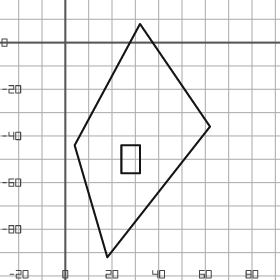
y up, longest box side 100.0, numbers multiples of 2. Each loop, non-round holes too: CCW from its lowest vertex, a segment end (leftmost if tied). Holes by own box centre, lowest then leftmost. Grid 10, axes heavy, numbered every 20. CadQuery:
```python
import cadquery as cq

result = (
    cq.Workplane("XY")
    .moveTo(18.0, -92.0)
    .lineTo(62.0, -36.0)
    .lineTo(32.0, 8.0)
    .lineTo(4.0, -44.0)
    .close()
    .moveTo(24.0, -56.0)
    .lineTo(32.0, -56.0)
    .lineTo(32.0, -44.0)
    .lineTo(24.0, -44.0)
    .close()
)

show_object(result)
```